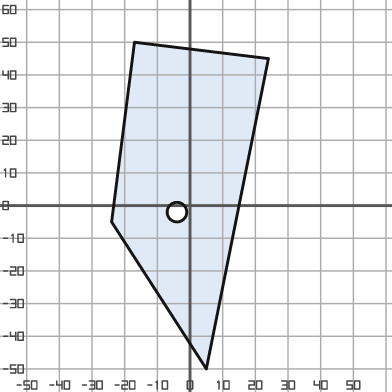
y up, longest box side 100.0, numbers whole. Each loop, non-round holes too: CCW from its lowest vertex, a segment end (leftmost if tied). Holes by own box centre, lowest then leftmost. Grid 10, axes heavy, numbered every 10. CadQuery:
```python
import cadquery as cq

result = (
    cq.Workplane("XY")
    .moveTo(5.0, -50.0)
    .lineTo(24.0, 45.0)
    .lineTo(-17.0, 50.0)
    .lineTo(-24.0, -5.0)
    .close()
    .moveTo(-4.0, -2.0)
    .circle(3.0)
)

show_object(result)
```